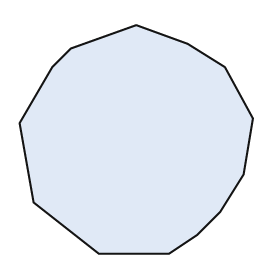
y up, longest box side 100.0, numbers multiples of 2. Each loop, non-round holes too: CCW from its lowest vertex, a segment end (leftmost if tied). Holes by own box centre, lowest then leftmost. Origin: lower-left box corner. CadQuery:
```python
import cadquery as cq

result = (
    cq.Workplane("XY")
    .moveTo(34.0, 0.0)
    .lineTo(64.0, 0.0)
    .lineTo(76.0, 8.0)
    .lineTo(86.0, 18.0)
    .lineTo(96.0, 34.0)
    .lineTo(100.0, 58.0)
    .lineTo(88.0, 80.0)
    .lineTo(72.0, 90.0)
    .lineTo(50.0, 98.0)
    .lineTo(22.0, 88.0)
    .lineTo(14.0, 80.0)
    .lineTo(0.0, 56.0)
    .lineTo(6.0, 22.0)
    .close()
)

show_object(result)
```